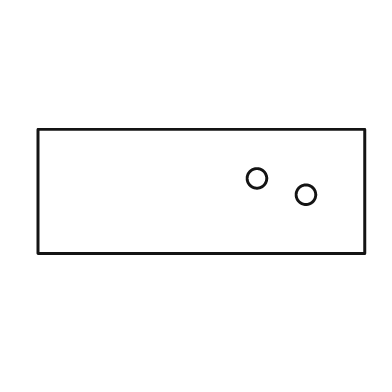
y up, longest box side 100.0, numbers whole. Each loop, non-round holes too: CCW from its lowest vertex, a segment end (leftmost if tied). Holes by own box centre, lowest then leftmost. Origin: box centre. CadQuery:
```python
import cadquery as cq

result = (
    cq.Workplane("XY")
    .moveTo(-50.0, -19.0)
    .lineTo(50.0, -19.0)
    .lineTo(50.0, 19.0)
    .lineTo(-50.0, 19.0)
    .close()
    .moveTo(32.0, -1.0)
    .circle(3.0)
    .moveTo(17.0, 4.0)
    .circle(3.0)
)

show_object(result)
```